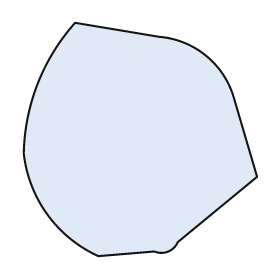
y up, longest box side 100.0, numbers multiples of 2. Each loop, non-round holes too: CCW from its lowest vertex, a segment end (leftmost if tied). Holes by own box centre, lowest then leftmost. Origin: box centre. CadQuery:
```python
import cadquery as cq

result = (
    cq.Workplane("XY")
    .moveTo(-18.0, -50.0)
    .lineTo(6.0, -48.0)
    .threePointArc((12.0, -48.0), (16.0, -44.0))
    .lineTo(50.0, -16.0)
    .lineTo(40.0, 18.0)
    .threePointArc((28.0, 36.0), (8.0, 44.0))
    .lineTo(-28.0, 50.0)
    .threePointArc((-44.0, 24.0), (-50.0, -6.0))
    .threePointArc((-40.0, -32.0), (-18.0, -50.0))
    .close()
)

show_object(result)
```